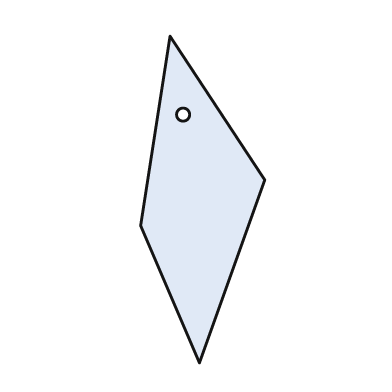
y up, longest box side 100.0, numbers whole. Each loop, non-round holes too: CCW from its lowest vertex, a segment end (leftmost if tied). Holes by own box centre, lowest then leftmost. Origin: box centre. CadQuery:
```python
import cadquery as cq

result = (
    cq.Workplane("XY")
    .moveTo(-1.0, -50.0)
    .lineTo(19.0, 6.0)
    .lineTo(-10.0, 50.0)
    .lineTo(-19.0, -8.0)
    .close()
    .moveTo(-6.0, 26.0)
    .circle(2.0)
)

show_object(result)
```